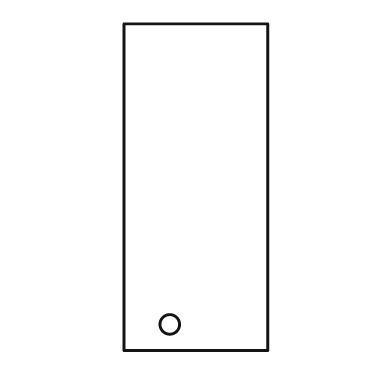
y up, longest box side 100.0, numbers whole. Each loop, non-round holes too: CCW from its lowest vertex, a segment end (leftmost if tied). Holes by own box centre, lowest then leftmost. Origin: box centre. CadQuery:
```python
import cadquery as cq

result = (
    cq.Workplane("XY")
    .moveTo(-22.0, -50.0)
    .lineTo(22.0, -50.0)
    .lineTo(22.0, 50.0)
    .lineTo(-22.0, 50.0)
    .close()
    .moveTo(-8.0, -42.0)
    .circle(3.0)
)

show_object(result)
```